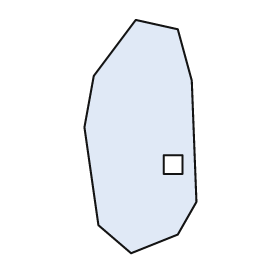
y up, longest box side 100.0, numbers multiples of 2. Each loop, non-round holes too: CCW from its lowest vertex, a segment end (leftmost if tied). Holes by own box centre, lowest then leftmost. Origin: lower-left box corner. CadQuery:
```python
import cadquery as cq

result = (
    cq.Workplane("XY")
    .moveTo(20.0, 0.0)
    .lineTo(40.0, 8.0)
    .lineTo(48.0, 22.0)
    .lineTo(46.0, 74.0)
    .lineTo(40.0, 96.0)
    .lineTo(22.0, 100.0)
    .lineTo(4.0, 76.0)
    .lineTo(0.0, 54.0)
    .lineTo(6.0, 12.0)
    .close()
    .moveTo(34.0, 34.0)
    .lineTo(42.0, 34.0)
    .lineTo(42.0, 42.0)
    .lineTo(34.0, 42.0)
    .close()
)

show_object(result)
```